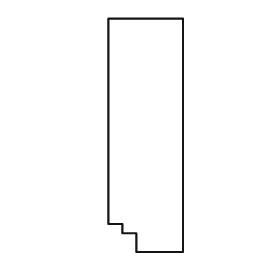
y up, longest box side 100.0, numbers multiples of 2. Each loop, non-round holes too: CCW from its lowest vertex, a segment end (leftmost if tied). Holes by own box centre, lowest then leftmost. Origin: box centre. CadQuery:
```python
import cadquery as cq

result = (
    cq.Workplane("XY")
    .moveTo(-4.0, -50.0)
    .lineTo(16.0, -50.0)
    .lineTo(16.0, 50.0)
    .lineTo(-16.0, 50.0)
    .lineTo(-16.0, -38.0)
    .lineTo(-10.0, -38.0)
    .lineTo(-10.0, -42.0)
    .lineTo(-4.0, -42.0)
    .close()
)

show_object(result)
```